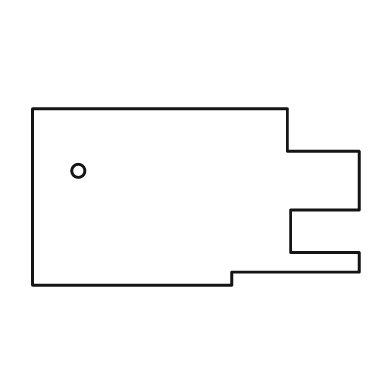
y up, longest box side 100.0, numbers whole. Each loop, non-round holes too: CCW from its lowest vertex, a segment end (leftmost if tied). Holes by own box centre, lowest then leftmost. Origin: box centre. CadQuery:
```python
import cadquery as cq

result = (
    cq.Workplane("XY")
    .moveTo(-50.0, -27.0)
    .lineTo(11.0, -27.0)
    .lineTo(11.0, -23.0)
    .lineTo(50.0, -23.0)
    .lineTo(50.0, -17.0)
    .lineTo(29.0, -17.0)
    .lineTo(29.0, -4.0)
    .lineTo(50.0, -4.0)
    .lineTo(50.0, 14.0)
    .lineTo(28.0, 14.0)
    .lineTo(28.0, 27.0)
    .lineTo(-50.0, 27.0)
    .close()
    .moveTo(-36.0, 8.0)
    .circle(2.0)
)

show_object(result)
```